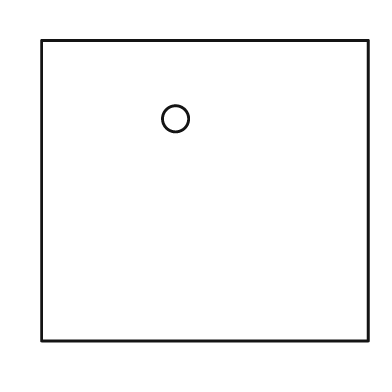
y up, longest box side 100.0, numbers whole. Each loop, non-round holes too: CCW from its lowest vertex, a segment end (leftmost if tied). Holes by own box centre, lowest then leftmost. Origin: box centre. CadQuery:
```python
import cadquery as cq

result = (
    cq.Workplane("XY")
    .moveTo(-50.0, -46.0)
    .lineTo(50.0, -46.0)
    .lineTo(50.0, 46.0)
    .lineTo(-50.0, 46.0)
    .close()
    .moveTo(-9.0, 22.0)
    .circle(4.0)
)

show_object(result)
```